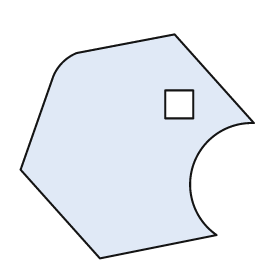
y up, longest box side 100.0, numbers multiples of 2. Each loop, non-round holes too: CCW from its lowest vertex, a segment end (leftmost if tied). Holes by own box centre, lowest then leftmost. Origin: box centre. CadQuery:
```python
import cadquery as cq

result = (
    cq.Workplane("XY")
    .moveTo(-16.0, -48.0)
    .lineTo(34.0, -38.0)
    .threePointArc((24.0, -8.0), (50.0, 10.0))
    .lineTo(16.0, 48.0)
    .lineTo(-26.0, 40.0)
    .threePointArc((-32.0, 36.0), (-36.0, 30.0))
    .lineTo(-50.0, -10.0)
    .close()
    .moveTo(12.0, 12.0)
    .lineTo(24.0, 12.0)
    .lineTo(24.0, 24.0)
    .lineTo(12.0, 24.0)
    .close()
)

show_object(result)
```